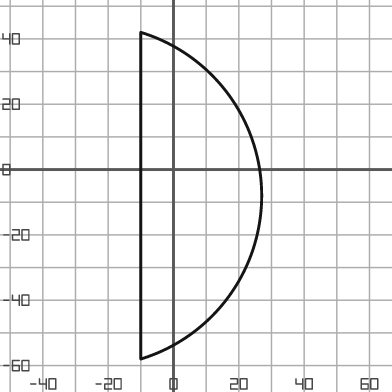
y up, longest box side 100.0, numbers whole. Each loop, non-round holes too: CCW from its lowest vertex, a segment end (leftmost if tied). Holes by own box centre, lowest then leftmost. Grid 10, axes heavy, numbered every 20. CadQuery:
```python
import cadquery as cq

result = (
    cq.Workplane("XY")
    .moveTo(-10.0, -58.0)
    .threePointArc((27.0, -8.0), (-10.0, 42.0))
    .close()
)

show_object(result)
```